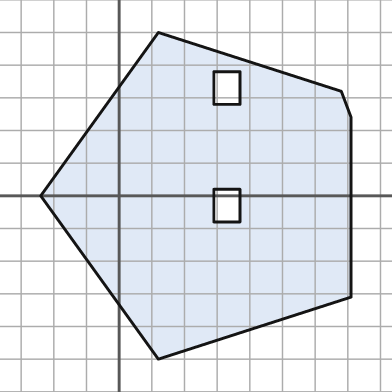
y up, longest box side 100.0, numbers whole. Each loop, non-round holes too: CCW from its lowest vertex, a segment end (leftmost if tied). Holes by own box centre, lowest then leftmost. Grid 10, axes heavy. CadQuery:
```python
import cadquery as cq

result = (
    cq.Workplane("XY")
    .moveTo(12.0, -50.0)
    .lineTo(71.0, -31.0)
    .lineTo(71.0, 24.0)
    .lineTo(68.0, 32.0)
    .lineTo(12.0, 50.0)
    .lineTo(-24.0, 0.0)
    .close()
    .moveTo(29.0, -8.0)
    .lineTo(37.0, -8.0)
    .lineTo(37.0, 2.0)
    .lineTo(29.0, 2.0)
    .close()
    .moveTo(29.0, 28.0)
    .lineTo(37.0, 28.0)
    .lineTo(37.0, 38.0)
    .lineTo(29.0, 38.0)
    .close()
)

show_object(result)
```